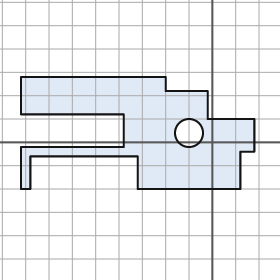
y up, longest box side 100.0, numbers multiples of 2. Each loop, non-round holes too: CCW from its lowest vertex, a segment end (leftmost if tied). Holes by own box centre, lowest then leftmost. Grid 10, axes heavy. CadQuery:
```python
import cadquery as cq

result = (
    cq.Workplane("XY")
    .moveTo(-82.0, -20.0)
    .lineTo(-78.0, -20.0)
    .lineTo(-78.0, -6.0)
    .lineTo(-32.0, -6.0)
    .lineTo(-32.0, -20.0)
    .lineTo(12.0, -20.0)
    .lineTo(12.0, -4.0)
    .lineTo(18.0, -4.0)
    .lineTo(18.0, 10.0)
    .lineTo(-2.0, 10.0)
    .lineTo(-2.0, 22.0)
    .lineTo(-20.0, 22.0)
    .lineTo(-20.0, 28.0)
    .lineTo(-82.0, 28.0)
    .lineTo(-82.0, 12.0)
    .lineTo(-38.0, 12.0)
    .lineTo(-38.0, -2.0)
    .lineTo(-82.0, -2.0)
    .close()
    .moveTo(-10.0, 4.0)
    .circle(6.0)
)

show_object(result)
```